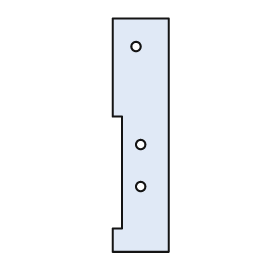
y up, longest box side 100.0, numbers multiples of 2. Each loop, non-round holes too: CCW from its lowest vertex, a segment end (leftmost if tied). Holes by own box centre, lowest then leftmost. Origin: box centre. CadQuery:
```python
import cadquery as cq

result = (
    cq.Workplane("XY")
    .moveTo(-12.0, -50.0)
    .lineTo(12.0, -50.0)
    .lineTo(12.0, 50.0)
    .lineTo(-12.0, 50.0)
    .lineTo(-12.0, 8.0)
    .lineTo(-8.0, 8.0)
    .lineTo(-8.0, -40.0)
    .lineTo(-12.0, -40.0)
    .close()
    .moveTo(0.0, -22.0)
    .circle(2.0)
    .moveTo(0.0, -4.0)
    .circle(2.0)
    .moveTo(-2.0, 38.0)
    .circle(2.0)
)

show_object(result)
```